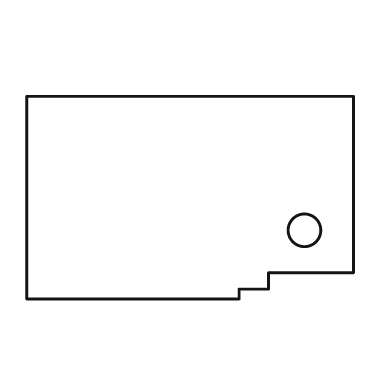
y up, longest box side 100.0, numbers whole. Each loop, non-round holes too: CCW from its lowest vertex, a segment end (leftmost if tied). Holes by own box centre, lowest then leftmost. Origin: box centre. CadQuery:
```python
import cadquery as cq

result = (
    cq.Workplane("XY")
    .moveTo(-50.0, -31.0)
    .lineTo(15.0, -31.0)
    .lineTo(15.0, -28.0)
    .lineTo(24.0, -28.0)
    .lineTo(24.0, -23.0)
    .lineTo(50.0, -23.0)
    .lineTo(50.0, 31.0)
    .lineTo(-50.0, 31.0)
    .close()
    .moveTo(35.0, -10.0)
    .circle(5.0)
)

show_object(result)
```